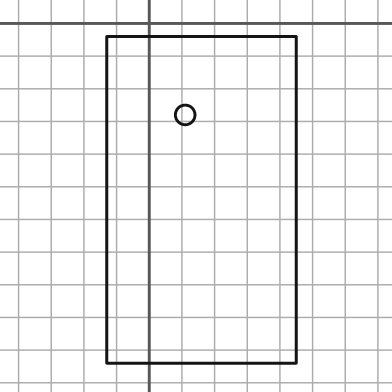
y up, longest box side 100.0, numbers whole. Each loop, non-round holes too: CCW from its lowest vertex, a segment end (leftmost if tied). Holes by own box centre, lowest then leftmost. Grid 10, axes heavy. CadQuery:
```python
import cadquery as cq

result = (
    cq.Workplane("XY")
    .moveTo(-13.0, -104.0)
    .lineTo(45.0, -104.0)
    .lineTo(45.0, -4.0)
    .lineTo(-13.0, -4.0)
    .close()
    .moveTo(11.0, -28.0)
    .circle(3.0)
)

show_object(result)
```